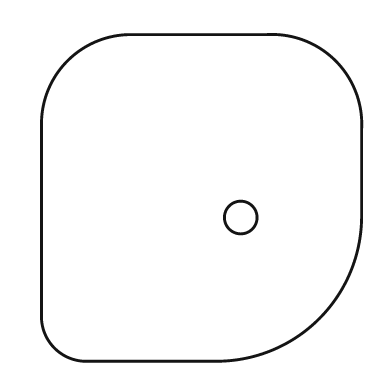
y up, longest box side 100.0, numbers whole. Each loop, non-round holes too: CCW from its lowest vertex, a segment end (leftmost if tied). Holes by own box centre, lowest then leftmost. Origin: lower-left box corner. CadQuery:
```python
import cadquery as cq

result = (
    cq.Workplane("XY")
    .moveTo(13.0, 0.0)
    .lineTo(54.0, 0.0)
    .threePointArc((85.0, 13.0), (98.0, 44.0))
    .lineTo(98.0, 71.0)
    .threePointArc((90.0, 92.0), (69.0, 100.0))
    .lineTo(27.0, 100.0)
    .threePointArc((8.0, 92.0), (0.0, 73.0))
    .lineTo(0.0, 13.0)
    .threePointArc((4.0, 4.0), (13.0, 0.0))
    .close()
    .moveTo(61.0, 44.0)
    .circle(5.0)
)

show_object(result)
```